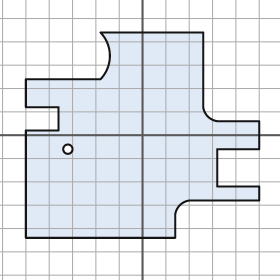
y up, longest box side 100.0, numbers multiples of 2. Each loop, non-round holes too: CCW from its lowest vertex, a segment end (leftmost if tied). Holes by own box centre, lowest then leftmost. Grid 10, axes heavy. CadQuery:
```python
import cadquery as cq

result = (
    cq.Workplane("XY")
    .moveTo(-50.0, -44.0)
    .lineTo(14.0, -44.0)
    .lineTo(14.0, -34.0)
    .threePointArc((16.0, -30.0), (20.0, -28.0))
    .lineTo(50.0, -28.0)
    .lineTo(50.0, -22.0)
    .lineTo(32.0, -22.0)
    .lineTo(32.0, -6.0)
    .lineTo(50.0, -6.0)
    .lineTo(50.0, 6.0)
    .lineTo(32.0, 6.0)
    .threePointArc((28.0, 8.0), (26.0, 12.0))
    .lineTo(26.0, 44.0)
    .lineTo(-18.0, 44.0)
    .threePointArc((-14.0, 34.0), (-18.0, 24.0))
    .lineTo(-50.0, 24.0)
    .lineTo(-50.0, 12.0)
    .lineTo(-36.0, 12.0)
    .lineTo(-36.0, 2.0)
    .lineTo(-50.0, 2.0)
    .close()
    .moveTo(-32.0, -6.0)
    .circle(2.0)
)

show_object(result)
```